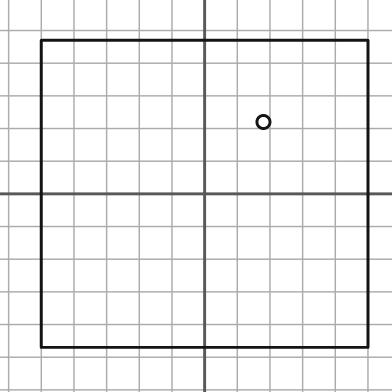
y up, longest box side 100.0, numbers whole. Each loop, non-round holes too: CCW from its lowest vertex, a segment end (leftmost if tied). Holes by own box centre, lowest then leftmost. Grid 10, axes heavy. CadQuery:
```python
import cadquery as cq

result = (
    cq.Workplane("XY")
    .moveTo(-50.0, -47.0)
    .lineTo(50.0, -47.0)
    .lineTo(50.0, 47.0)
    .lineTo(-50.0, 47.0)
    .close()
    .moveTo(18.0, 22.0)
    .circle(2.0)
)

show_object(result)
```